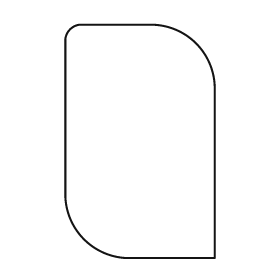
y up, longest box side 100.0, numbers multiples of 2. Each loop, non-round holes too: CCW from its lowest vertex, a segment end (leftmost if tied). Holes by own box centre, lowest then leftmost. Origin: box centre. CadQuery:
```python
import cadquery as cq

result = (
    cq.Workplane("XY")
    .moveTo(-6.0, -50.0)
    .lineTo(32.0, -50.0)
    .lineTo(32.0, 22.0)
    .threePointArc((24.0, 42.0), (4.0, 50.0))
    .lineTo(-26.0, 50.0)
    .threePointArc((-30.0, 48.0), (-32.0, 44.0))
    .lineTo(-32.0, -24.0)
    .threePointArc((-24.0, -42.0), (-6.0, -50.0))
    .close()
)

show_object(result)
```